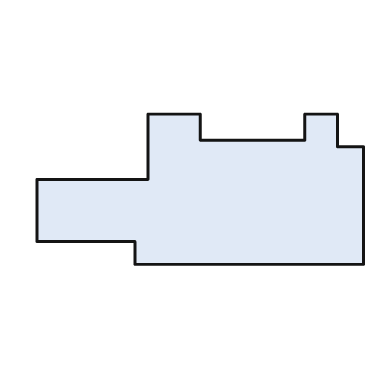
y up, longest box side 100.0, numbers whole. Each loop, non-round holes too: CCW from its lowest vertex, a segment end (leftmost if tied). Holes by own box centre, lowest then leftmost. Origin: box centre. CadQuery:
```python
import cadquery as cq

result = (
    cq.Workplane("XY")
    .moveTo(-20.0, -23.0)
    .lineTo(50.0, -23.0)
    .lineTo(50.0, 13.0)
    .lineTo(42.0, 13.0)
    .lineTo(42.0, 23.0)
    .lineTo(32.0, 23.0)
    .lineTo(32.0, 15.0)
    .lineTo(0.0, 15.0)
    .lineTo(0.0, 23.0)
    .lineTo(-16.0, 23.0)
    .lineTo(-16.0, 3.0)
    .lineTo(-50.0, 3.0)
    .lineTo(-50.0, -16.0)
    .lineTo(-20.0, -16.0)
    .close()
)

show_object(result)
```